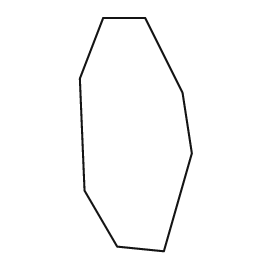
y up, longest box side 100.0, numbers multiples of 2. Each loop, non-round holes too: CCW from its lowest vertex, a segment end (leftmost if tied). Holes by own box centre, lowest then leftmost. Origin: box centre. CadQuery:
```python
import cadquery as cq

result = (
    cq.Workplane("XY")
    .moveTo(12.0, -50.0)
    .lineTo(24.0, -8.0)
    .lineTo(20.0, 18.0)
    .lineTo(4.0, 50.0)
    .lineTo(-14.0, 50.0)
    .lineTo(-24.0, 24.0)
    .lineTo(-22.0, -24.0)
    .lineTo(-8.0, -48.0)
    .close()
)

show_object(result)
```